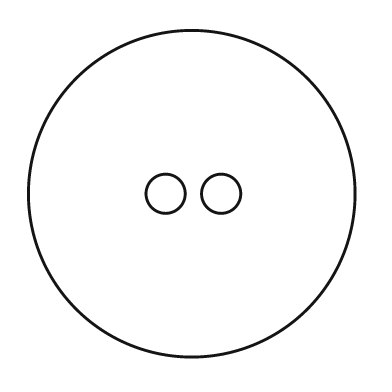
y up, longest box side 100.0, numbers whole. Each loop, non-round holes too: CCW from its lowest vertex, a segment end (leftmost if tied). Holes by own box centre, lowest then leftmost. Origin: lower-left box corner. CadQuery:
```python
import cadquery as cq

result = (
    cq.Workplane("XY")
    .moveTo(50.0, 50.0)
    .circle(50.0)
    .moveTo(42.0, 50.0)
    .circle(6.0)
    .moveTo(59.0, 50.0)
    .circle(6.0)
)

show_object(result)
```